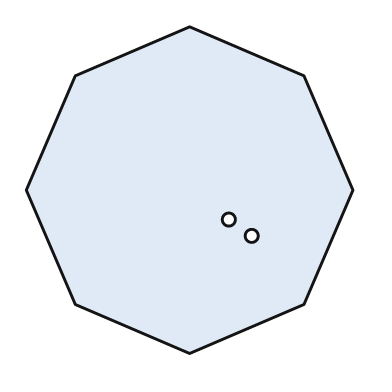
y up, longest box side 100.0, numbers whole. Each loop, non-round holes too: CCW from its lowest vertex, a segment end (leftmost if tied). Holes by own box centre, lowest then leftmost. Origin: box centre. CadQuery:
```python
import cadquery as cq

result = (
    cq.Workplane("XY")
    .moveTo(0.0, -50.0)
    .lineTo(35.0, -35.0)
    .lineTo(50.0, 0.0)
    .lineTo(35.0, 35.0)
    .lineTo(0.0, 50.0)
    .lineTo(-35.0, 35.0)
    .lineTo(-50.0, 0.0)
    .lineTo(-35.0, -35.0)
    .close()
    .moveTo(19.0, -14.0)
    .circle(2.0)
    .moveTo(12.0, -9.0)
    .circle(2.0)
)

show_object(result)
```